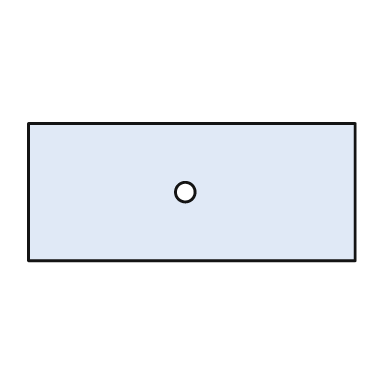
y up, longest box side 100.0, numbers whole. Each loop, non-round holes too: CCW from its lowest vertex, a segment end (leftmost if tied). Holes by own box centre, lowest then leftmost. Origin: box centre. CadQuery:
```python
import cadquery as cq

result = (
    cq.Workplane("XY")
    .moveTo(-50.0, -21.0)
    .lineTo(50.0, -21.0)
    .lineTo(50.0, 21.0)
    .lineTo(-50.0, 21.0)
    .close()
    .moveTo(-2.0, 0.0)
    .circle(3.0)
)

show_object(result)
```